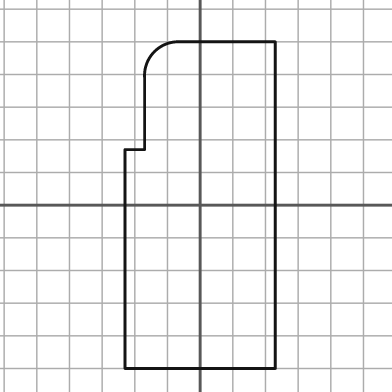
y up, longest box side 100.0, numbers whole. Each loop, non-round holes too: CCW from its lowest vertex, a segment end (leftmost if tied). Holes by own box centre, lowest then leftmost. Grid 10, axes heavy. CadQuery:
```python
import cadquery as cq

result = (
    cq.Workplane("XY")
    .moveTo(-23.0, -50.0)
    .lineTo(23.0, -50.0)
    .lineTo(23.0, 50.0)
    .lineTo(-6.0, 50.0)
    .threePointArc((-14.0, 47.0), (-17.0, 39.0))
    .lineTo(-17.0, 17.0)
    .lineTo(-23.0, 17.0)
    .close()
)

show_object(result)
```